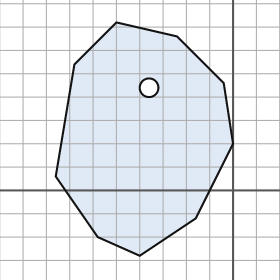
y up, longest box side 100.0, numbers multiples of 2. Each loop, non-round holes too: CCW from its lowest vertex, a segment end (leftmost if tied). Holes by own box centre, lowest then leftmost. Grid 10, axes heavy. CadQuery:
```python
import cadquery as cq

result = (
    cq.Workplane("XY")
    .moveTo(-40.0, -28.0)
    .lineTo(-16.0, -12.0)
    .lineTo(0.0, 20.0)
    .lineTo(-4.0, 46.0)
    .lineTo(-24.0, 66.0)
    .lineTo(-50.0, 72.0)
    .lineTo(-68.0, 54.0)
    .lineTo(-76.0, 6.0)
    .lineTo(-58.0, -20.0)
    .close()
    .moveTo(-36.0, 44.0)
    .circle(4.0)
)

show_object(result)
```